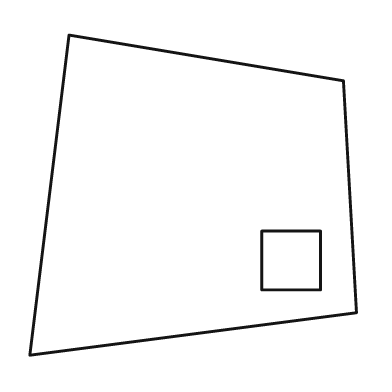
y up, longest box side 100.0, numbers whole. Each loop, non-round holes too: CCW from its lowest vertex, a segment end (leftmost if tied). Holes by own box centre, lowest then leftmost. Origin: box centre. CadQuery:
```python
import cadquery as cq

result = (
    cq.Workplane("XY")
    .moveTo(-50.0, -49.0)
    .lineTo(50.0, -36.0)
    .lineTo(46.0, 35.0)
    .lineTo(-38.0, 49.0)
    .close()
    .moveTo(21.0, -29.0)
    .lineTo(39.0, -29.0)
    .lineTo(39.0, -11.0)
    .lineTo(21.0, -11.0)
    .close()
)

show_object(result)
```